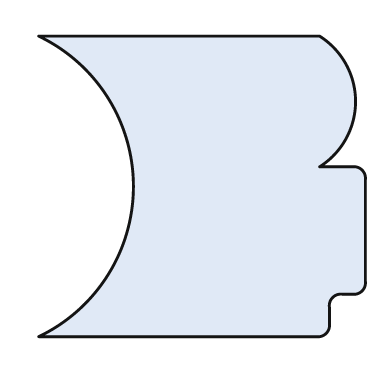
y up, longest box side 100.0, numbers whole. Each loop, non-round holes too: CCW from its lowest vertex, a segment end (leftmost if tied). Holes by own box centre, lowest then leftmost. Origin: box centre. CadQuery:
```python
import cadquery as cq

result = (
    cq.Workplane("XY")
    .moveTo(-50.0, -46.0)
    .lineTo(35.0, -46.0)
    .threePointArc((38.0, -45.0), (39.0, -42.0))
    .lineTo(39.0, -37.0)
    .threePointArc((40.0, -34.0), (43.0, -33.0))
    .lineTo(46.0, -33.0)
    .threePointArc((49.0, -32.0), (50.0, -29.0))
    .lineTo(50.0, 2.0)
    .threePointArc((49.0, 5.0), (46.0, 6.0))
    .lineTo(36.0, 6.0)
    .threePointArc((47.0, 26.0), (36.0, 46.0))
    .lineTo(-50.0, 46.0)
    .threePointArc((-21.0, 0.0), (-50.0, -46.0))
    .close()
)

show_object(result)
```